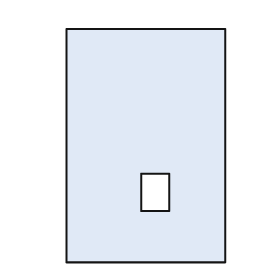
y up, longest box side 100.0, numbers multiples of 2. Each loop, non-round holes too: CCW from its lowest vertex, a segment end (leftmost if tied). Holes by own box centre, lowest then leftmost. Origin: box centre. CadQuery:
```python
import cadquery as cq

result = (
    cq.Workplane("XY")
    .moveTo(-34.0, -50.0)
    .lineTo(34.0, -50.0)
    .lineTo(34.0, 50.0)
    .lineTo(-34.0, 50.0)
    .close()
    .moveTo(-2.0, -28.0)
    .lineTo(10.0, -28.0)
    .lineTo(10.0, -12.0)
    .lineTo(-2.0, -12.0)
    .close()
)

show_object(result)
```